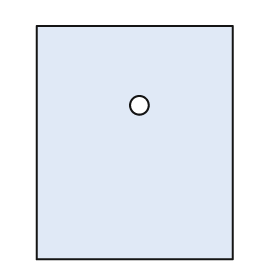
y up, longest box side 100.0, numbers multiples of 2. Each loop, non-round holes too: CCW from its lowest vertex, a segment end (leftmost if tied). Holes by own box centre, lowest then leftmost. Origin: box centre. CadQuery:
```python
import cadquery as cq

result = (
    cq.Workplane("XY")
    .moveTo(-42.0, -50.0)
    .lineTo(42.0, -50.0)
    .lineTo(42.0, 50.0)
    .lineTo(-42.0, 50.0)
    .close()
    .moveTo(2.0, 16.0)
    .circle(4.0)
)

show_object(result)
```